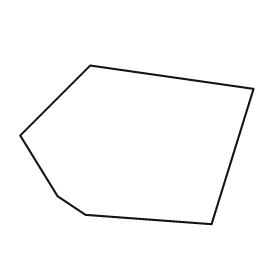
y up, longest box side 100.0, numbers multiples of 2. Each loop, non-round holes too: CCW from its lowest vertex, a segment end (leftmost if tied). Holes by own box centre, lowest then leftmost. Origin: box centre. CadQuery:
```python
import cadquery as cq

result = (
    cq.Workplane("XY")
    .moveTo(32.0, -34.0)
    .lineTo(50.0, 24.0)
    .lineTo(-20.0, 34.0)
    .lineTo(-50.0, 4.0)
    .lineTo(-34.0, -22.0)
    .lineTo(-22.0, -30.0)
    .close()
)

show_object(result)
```